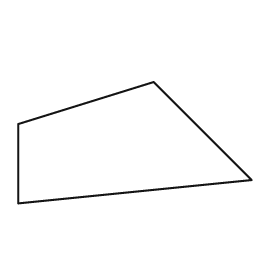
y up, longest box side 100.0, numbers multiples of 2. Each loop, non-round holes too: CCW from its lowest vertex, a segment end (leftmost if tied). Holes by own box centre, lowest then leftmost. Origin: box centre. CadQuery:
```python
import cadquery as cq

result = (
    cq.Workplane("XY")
    .moveTo(-50.0, -26.0)
    .lineTo(50.0, -16.0)
    .lineTo(8.0, 26.0)
    .lineTo(-50.0, 8.0)
    .close()
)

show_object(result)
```